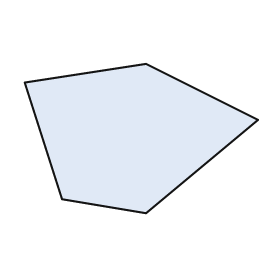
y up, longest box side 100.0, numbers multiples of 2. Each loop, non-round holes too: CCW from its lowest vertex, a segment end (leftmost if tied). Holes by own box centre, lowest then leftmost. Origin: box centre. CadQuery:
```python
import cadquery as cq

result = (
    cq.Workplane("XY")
    .moveTo(2.0, -32.0)
    .lineTo(50.0, 8.0)
    .lineTo(2.0, 32.0)
    .lineTo(-50.0, 24.0)
    .lineTo(-34.0, -26.0)
    .close()
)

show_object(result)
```